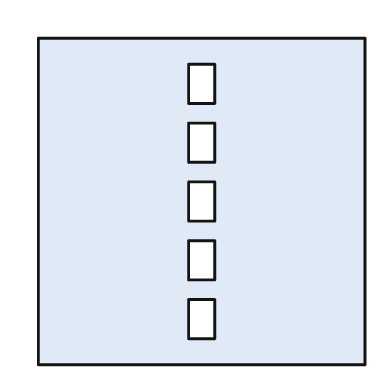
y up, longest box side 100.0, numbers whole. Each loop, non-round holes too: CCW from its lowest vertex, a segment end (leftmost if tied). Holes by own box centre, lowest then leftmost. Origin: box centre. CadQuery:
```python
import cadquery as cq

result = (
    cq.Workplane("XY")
    .moveTo(-50.0, -50.0)
    .lineTo(50.0, -50.0)
    .lineTo(50.0, 50.0)
    .lineTo(-50.0, 50.0)
    .close()
    .moveTo(-4.0, -42.0)
    .lineTo(4.0, -42.0)
    .lineTo(4.0, -30.0)
    .lineTo(-4.0, -30.0)
    .close()
    .moveTo(-4.0, -24.0)
    .lineTo(4.0, -24.0)
    .lineTo(4.0, -12.0)
    .lineTo(-4.0, -12.0)
    .close()
    .moveTo(-4.0, -6.0)
    .lineTo(4.0, -6.0)
    .lineTo(4.0, 6.0)
    .lineTo(-4.0, 6.0)
    .close()
    .moveTo(-4.0, 12.0)
    .lineTo(4.0, 12.0)
    .lineTo(4.0, 24.0)
    .lineTo(-4.0, 24.0)
    .close()
    .moveTo(-4.0, 30.0)
    .lineTo(4.0, 30.0)
    .lineTo(4.0, 42.0)
    .lineTo(-4.0, 42.0)
    .close()
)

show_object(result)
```